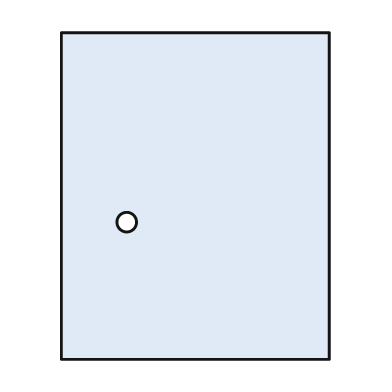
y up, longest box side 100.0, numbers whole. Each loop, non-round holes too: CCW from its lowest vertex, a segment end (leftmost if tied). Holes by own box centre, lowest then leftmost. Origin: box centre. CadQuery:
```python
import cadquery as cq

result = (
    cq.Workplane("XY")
    .moveTo(-41.0, -50.0)
    .lineTo(41.0, -50.0)
    .lineTo(41.0, 50.0)
    .lineTo(-41.0, 50.0)
    .close()
    .moveTo(-21.0, -8.0)
    .circle(3.0)
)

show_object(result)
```